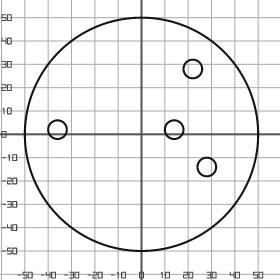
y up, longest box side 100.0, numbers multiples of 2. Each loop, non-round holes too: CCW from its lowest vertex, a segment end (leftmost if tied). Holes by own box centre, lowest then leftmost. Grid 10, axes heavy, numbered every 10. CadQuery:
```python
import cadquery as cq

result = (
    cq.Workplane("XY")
    .moveTo(0.0, 0.0)
    .circle(50.0)
    .moveTo(28.0, -14.0)
    .circle(4.0)
    .moveTo(-36.0, 2.0)
    .circle(4.0)
    .moveTo(14.0, 2.0)
    .circle(4.0)
    .moveTo(22.0, 28.0)
    .circle(4.0)
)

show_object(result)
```